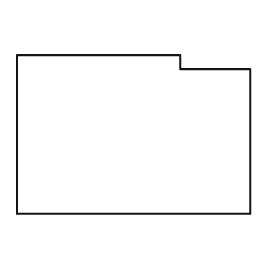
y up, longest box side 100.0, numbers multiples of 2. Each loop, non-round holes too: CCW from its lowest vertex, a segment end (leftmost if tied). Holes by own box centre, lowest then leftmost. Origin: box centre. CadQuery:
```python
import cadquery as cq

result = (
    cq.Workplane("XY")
    .moveTo(-50.0, -34.0)
    .lineTo(50.0, -34.0)
    .lineTo(50.0, 28.0)
    .lineTo(20.0, 28.0)
    .lineTo(20.0, 34.0)
    .lineTo(-50.0, 34.0)
    .close()
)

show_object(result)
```